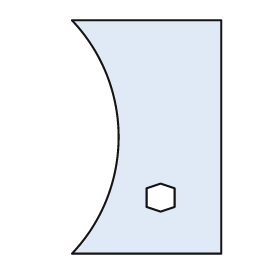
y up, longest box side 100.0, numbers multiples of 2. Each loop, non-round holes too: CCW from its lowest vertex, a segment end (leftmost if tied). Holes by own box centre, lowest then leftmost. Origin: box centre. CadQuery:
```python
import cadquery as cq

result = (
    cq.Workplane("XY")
    .moveTo(-32.0, -50.0)
    .lineTo(32.0, -50.0)
    .lineTo(32.0, 50.0)
    .lineTo(-32.0, 50.0)
    .threePointArc((-12.0, 0.0), (-32.0, -50.0))
    .close()
    .moveTo(6.0, -32.0)
    .lineTo(12.0, -30.0)
    .lineTo(12.0, -22.0)
    .lineTo(6.0, -20.0)
    .lineTo(0.0, -22.0)
    .lineTo(0.0, -30.0)
    .close()
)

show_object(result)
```